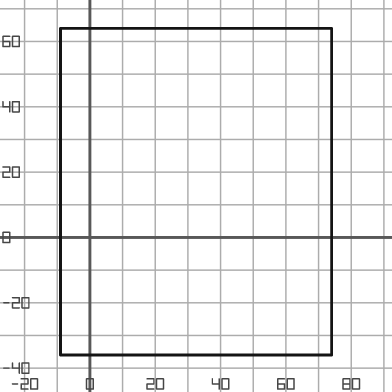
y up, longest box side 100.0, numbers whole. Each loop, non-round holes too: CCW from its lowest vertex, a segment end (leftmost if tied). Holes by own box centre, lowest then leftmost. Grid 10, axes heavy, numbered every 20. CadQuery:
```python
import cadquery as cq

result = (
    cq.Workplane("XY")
    .moveTo(-9.0, -36.0)
    .lineTo(74.0, -36.0)
    .lineTo(74.0, 64.0)
    .lineTo(-9.0, 64.0)
    .close()
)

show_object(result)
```